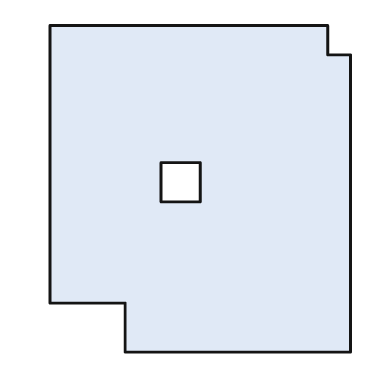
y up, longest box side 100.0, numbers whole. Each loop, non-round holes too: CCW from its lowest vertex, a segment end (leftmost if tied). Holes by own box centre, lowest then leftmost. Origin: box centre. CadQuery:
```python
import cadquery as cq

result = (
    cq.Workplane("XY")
    .moveTo(-23.0, -50.0)
    .lineTo(46.0, -50.0)
    .lineTo(46.0, 41.0)
    .lineTo(39.0, 41.0)
    .lineTo(39.0, 50.0)
    .lineTo(-46.0, 50.0)
    .lineTo(-46.0, -35.0)
    .lineTo(-23.0, -35.0)
    .close()
    .moveTo(-12.0, -4.0)
    .lineTo(0.0, -4.0)
    .lineTo(0.0, 8.0)
    .lineTo(-12.0, 8.0)
    .close()
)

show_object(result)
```